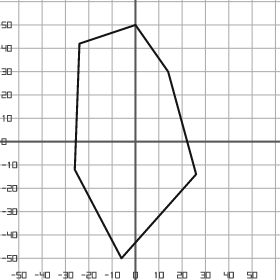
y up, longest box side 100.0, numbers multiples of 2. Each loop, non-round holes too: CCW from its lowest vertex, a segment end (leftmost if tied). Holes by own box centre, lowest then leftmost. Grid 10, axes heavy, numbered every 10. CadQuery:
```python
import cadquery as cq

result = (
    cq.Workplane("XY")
    .moveTo(-6.0, -50.0)
    .lineTo(26.0, -14.0)
    .lineTo(14.0, 30.0)
    .lineTo(0.0, 50.0)
    .lineTo(-24.0, 42.0)
    .lineTo(-26.0, -12.0)
    .close()
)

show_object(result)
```